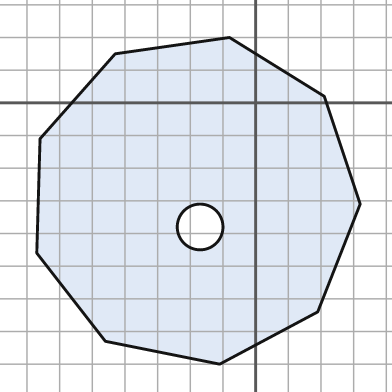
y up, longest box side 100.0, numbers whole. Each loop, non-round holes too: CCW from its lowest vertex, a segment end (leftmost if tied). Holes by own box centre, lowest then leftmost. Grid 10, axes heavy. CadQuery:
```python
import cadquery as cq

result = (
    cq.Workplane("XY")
    .moveTo(-11.0, -80.0)
    .lineTo(19.0, -64.0)
    .lineTo(32.0, -31.0)
    .lineTo(21.0, 2.0)
    .lineTo(-8.0, 20.0)
    .lineTo(-43.0, 15.0)
    .lineTo(-66.0, -11.0)
    .lineTo(-67.0, -46.0)
    .lineTo(-46.0, -73.0)
    .close()
    .moveTo(-17.0, -38.0)
    .circle(7.0)
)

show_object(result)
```